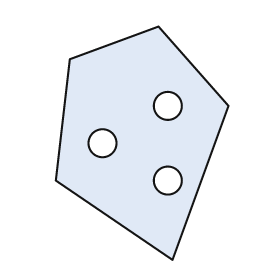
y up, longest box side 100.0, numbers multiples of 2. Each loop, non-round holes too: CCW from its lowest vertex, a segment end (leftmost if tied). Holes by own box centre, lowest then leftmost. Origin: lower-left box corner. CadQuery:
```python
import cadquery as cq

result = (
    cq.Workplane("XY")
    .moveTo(50.0, 0.0)
    .lineTo(74.0, 66.0)
    .lineTo(44.0, 100.0)
    .lineTo(6.0, 86.0)
    .lineTo(0.0, 34.0)
    .close()
    .moveTo(48.0, 34.0)
    .circle(6.0)
    .moveTo(20.0, 50.0)
    .circle(6.0)
    .moveTo(48.0, 66.0)
    .circle(6.0)
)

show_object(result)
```